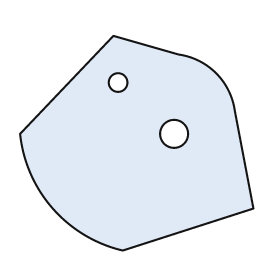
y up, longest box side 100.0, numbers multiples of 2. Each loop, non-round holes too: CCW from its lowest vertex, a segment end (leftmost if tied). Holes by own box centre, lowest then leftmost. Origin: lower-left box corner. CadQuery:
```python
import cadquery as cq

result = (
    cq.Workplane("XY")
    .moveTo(44.0, 0.0)
    .lineTo(100.0, 18.0)
    .lineTo(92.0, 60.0)
    .threePointArc((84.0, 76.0), (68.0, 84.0))
    .lineTo(40.0, 92.0)
    .lineTo(0.0, 50.0)
    .threePointArc((14.0, 18.0), (44.0, 0.0))
    .close()
    .moveTo(66.0, 50.0)
    .circle(6.0)
    .moveTo(42.0, 72.0)
    .circle(4.0)
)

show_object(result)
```